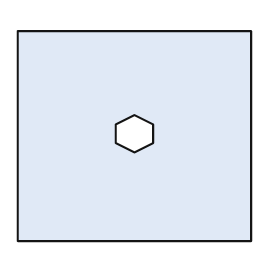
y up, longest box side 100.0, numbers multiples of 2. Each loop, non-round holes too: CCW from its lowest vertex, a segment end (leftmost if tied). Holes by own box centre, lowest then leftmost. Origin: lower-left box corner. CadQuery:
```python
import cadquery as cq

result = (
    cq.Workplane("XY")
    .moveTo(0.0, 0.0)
    .lineTo(100.0, 0.0)
    .lineTo(100.0, 90.0)
    .lineTo(0.0, 90.0)
    .close()
    .moveTo(50.0, 38.0)
    .lineTo(58.0, 42.0)
    .lineTo(58.0, 50.0)
    .lineTo(50.0, 54.0)
    .lineTo(42.0, 50.0)
    .lineTo(42.0, 42.0)
    .close()
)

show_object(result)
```